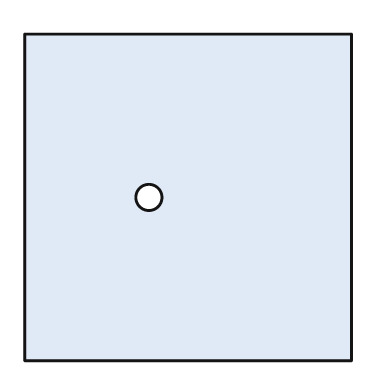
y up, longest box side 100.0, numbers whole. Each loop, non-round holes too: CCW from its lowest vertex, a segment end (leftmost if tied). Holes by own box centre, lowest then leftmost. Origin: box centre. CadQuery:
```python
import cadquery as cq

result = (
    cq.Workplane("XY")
    .moveTo(-50.0, -50.0)
    .lineTo(50.0, -50.0)
    .lineTo(50.0, 50.0)
    .lineTo(-50.0, 50.0)
    .close()
    .moveTo(-12.0, 0.0)
    .circle(4.0)
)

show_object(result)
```